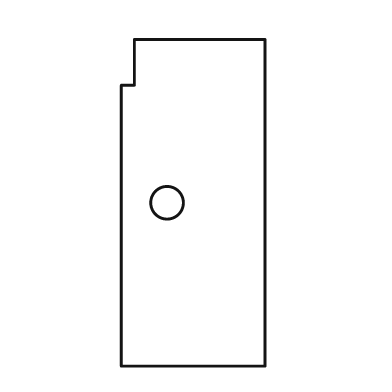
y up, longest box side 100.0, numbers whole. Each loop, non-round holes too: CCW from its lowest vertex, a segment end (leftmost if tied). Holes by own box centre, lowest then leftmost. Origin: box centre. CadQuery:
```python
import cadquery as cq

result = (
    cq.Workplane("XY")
    .moveTo(-22.0, -50.0)
    .lineTo(22.0, -50.0)
    .lineTo(22.0, 50.0)
    .lineTo(-18.0, 50.0)
    .lineTo(-18.0, 36.0)
    .lineTo(-22.0, 36.0)
    .close()
    .moveTo(-8.0, 0.0)
    .circle(5.0)
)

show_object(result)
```